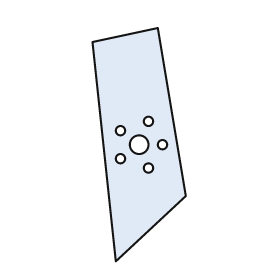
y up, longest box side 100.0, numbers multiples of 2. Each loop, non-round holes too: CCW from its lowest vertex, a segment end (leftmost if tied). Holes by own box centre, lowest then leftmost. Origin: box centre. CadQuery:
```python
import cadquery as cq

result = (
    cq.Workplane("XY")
    .moveTo(-10.0, -50.0)
    .lineTo(20.0, -22.0)
    .lineTo(8.0, 50.0)
    .lineTo(-20.0, 44.0)
    .close()
    .moveTo(4.0, -10.0)
    .circle(2.0)
    .moveTo(-8.0, -6.0)
    .circle(2.0)
    .moveTo(0.0, 0.0)
    .circle(4.0)
    .moveTo(10.0, 0.0)
    .circle(2.0)
    .moveTo(-8.0, 6.0)
    .circle(2.0)
    .moveTo(4.0, 10.0)
    .circle(2.0)
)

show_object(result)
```